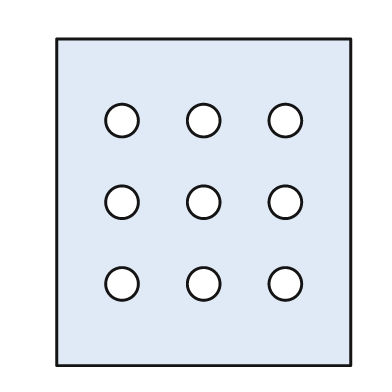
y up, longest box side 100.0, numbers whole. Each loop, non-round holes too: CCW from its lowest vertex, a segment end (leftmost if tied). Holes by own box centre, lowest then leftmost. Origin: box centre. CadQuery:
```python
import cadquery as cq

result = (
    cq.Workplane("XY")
    .moveTo(-45.0, -50.0)
    .lineTo(45.0, -50.0)
    .lineTo(45.0, 50.0)
    .lineTo(-45.0, 50.0)
    .close()
    .moveTo(-25.0, -25.0)
    .circle(5.0)
    .moveTo(0.0, -25.0)
    .circle(5.0)
    .moveTo(25.0, -25.0)
    .circle(5.0)
    .moveTo(-25.0, 0.0)
    .circle(5.0)
    .moveTo(0.0, 0.0)
    .circle(5.0)
    .moveTo(25.0, 0.0)
    .circle(5.0)
    .moveTo(-25.0, 25.0)
    .circle(5.0)
    .moveTo(0.0, 25.0)
    .circle(5.0)
    .moveTo(25.0, 25.0)
    .circle(5.0)
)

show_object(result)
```